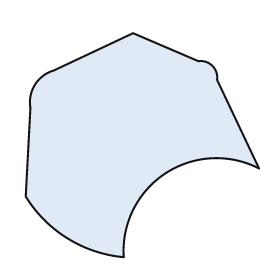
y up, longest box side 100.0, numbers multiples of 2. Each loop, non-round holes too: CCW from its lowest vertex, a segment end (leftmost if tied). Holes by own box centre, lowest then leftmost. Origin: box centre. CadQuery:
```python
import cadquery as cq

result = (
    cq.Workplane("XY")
    .moveTo(-8.0, -48.0)
    .threePointArc((10.0, -12.0), (50.0, -10.0))
    .lineTo(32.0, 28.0)
    .threePointArc((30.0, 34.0), (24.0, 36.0))
    .lineTo(-4.0, 48.0)
    .lineTo(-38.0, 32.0)
    .threePointArc((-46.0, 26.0), (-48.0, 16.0))
    .lineTo(-50.0, -22.0)
    .threePointArc((-32.0, -40.0), (-8.0, -48.0))
    .close()
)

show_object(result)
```